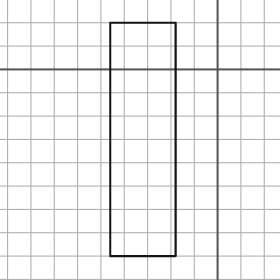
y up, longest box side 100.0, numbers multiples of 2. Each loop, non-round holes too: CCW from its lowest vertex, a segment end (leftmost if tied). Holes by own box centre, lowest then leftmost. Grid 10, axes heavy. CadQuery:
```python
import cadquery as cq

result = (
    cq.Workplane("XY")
    .moveTo(-46.0, -80.0)
    .lineTo(-18.0, -80.0)
    .lineTo(-18.0, 20.0)
    .lineTo(-46.0, 20.0)
    .close()
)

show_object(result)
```